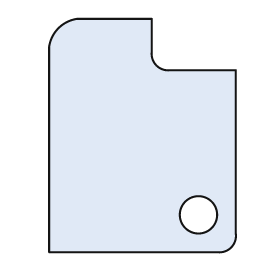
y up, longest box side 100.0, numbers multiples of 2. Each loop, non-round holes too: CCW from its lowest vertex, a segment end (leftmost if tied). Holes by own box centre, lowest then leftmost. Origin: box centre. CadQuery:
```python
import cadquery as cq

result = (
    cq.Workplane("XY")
    .moveTo(-40.0, -50.0)
    .lineTo(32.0, -50.0)
    .threePointArc((38.0, -48.0), (40.0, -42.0))
    .lineTo(40.0, 28.0)
    .lineTo(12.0, 28.0)
    .threePointArc((6.0, 30.0), (4.0, 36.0))
    .lineTo(4.0, 50.0)
    .lineTo(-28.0, 50.0)
    .threePointArc((-36.0, 46.0), (-40.0, 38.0))
    .close()
    .moveTo(24.0, -34.0)
    .circle(8.0)
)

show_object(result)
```